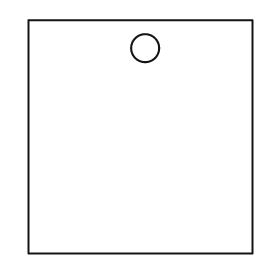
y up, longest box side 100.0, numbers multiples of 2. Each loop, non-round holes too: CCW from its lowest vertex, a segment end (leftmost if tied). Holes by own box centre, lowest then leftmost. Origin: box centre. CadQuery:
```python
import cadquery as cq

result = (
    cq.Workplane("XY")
    .moveTo(-48.0, -50.0)
    .lineTo(48.0, -50.0)
    .lineTo(48.0, 50.0)
    .lineTo(-48.0, 50.0)
    .close()
    .moveTo(2.0, 38.0)
    .circle(6.0)
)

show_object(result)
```